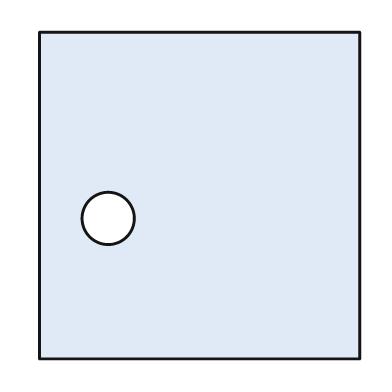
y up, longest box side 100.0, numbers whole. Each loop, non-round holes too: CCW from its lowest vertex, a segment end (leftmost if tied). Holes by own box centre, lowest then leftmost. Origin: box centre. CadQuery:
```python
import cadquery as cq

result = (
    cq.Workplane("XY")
    .moveTo(-49.0, -50.0)
    .lineTo(49.0, -50.0)
    .lineTo(49.0, 50.0)
    .lineTo(-49.0, 50.0)
    .close()
    .moveTo(-28.0, -7.0)
    .circle(8.0)
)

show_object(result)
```